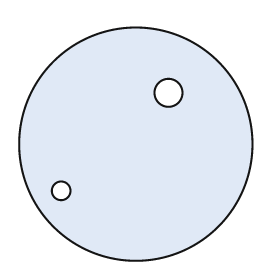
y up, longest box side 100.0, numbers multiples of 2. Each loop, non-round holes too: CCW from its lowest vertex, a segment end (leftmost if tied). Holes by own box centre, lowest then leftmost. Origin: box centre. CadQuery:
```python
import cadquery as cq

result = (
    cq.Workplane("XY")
    .moveTo(0.0, 0.0)
    .circle(50.0)
    .moveTo(-32.0, -20.0)
    .circle(4.0)
    .moveTo(14.0, 22.0)
    .circle(6.0)
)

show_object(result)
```